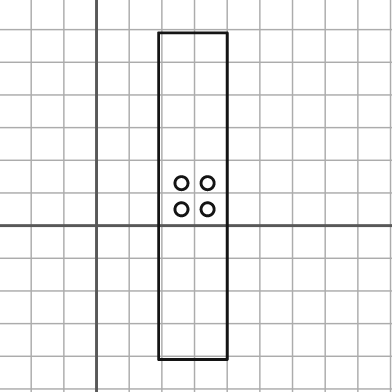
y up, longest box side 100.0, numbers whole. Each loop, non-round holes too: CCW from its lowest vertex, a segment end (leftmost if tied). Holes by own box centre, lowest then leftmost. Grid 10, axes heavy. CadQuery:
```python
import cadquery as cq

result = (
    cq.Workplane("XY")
    .moveTo(19.0, -41.0)
    .lineTo(40.0, -41.0)
    .lineTo(40.0, 59.0)
    .lineTo(19.0, 59.0)
    .close()
    .moveTo(26.0, 5.0)
    .circle(2.0)
    .moveTo(34.0, 5.0)
    .circle(2.0)
    .moveTo(26.0, 13.0)
    .circle(2.0)
    .moveTo(34.0, 13.0)
    .circle(2.0)
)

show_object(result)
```